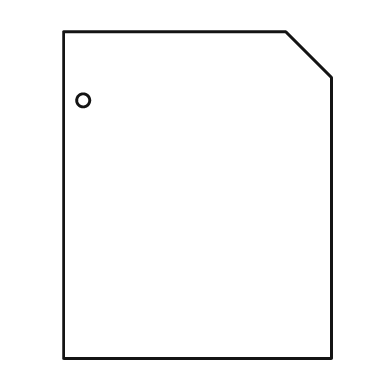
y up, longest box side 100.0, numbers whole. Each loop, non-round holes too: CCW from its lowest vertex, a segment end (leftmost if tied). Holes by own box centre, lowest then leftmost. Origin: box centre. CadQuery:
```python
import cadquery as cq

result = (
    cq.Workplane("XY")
    .moveTo(-41.0, -50.0)
    .lineTo(41.0, -50.0)
    .lineTo(41.0, 36.0)
    .lineTo(27.0, 50.0)
    .lineTo(-41.0, 50.0)
    .close()
    .moveTo(-35.0, 29.0)
    .circle(2.0)
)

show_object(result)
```